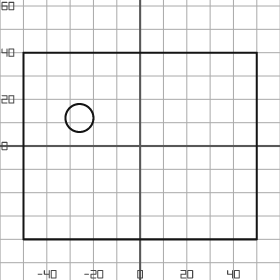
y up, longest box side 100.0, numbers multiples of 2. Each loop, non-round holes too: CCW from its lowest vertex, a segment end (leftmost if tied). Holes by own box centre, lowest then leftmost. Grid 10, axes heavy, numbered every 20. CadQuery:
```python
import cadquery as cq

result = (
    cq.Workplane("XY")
    .moveTo(-50.0, -40.0)
    .lineTo(50.0, -40.0)
    .lineTo(50.0, 40.0)
    .lineTo(-50.0, 40.0)
    .close()
    .moveTo(-26.0, 12.0)
    .circle(6.0)
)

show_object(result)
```